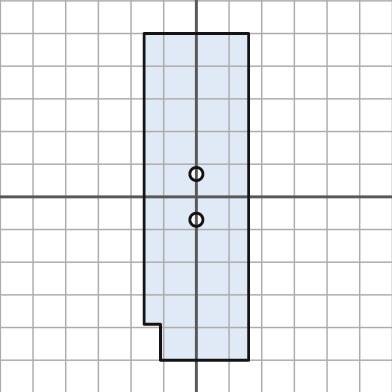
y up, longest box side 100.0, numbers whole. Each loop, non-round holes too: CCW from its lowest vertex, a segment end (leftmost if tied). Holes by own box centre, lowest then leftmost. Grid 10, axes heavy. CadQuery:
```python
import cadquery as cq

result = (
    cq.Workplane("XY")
    .moveTo(-11.0, -50.0)
    .lineTo(16.0, -50.0)
    .lineTo(16.0, 50.0)
    .lineTo(-16.0, 50.0)
    .lineTo(-16.0, -39.0)
    .lineTo(-11.0, -39.0)
    .close()
    .moveTo(0.0, -7.0)
    .circle(2.0)
    .moveTo(0.0, 7.0)
    .circle(2.0)
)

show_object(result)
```